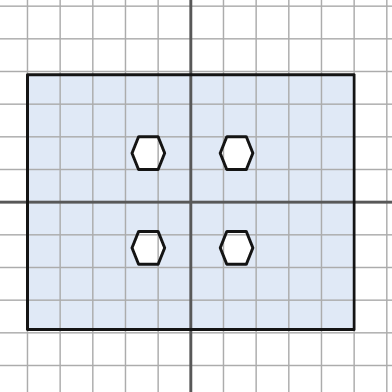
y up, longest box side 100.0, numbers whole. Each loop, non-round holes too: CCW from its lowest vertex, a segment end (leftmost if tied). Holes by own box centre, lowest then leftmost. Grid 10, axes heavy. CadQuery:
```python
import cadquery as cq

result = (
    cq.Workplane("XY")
    .moveTo(-50.0, -39.0)
    .lineTo(50.0, -39.0)
    .lineTo(50.0, 39.0)
    .lineTo(-50.0, 39.0)
    .close()
    .moveTo(-16.0, -19.0)
    .lineTo(-10.0, -19.0)
    .lineTo(-8.0, -14.0)
    .lineTo(-10.0, -9.0)
    .lineTo(-16.0, -9.0)
    .lineTo(-18.0, -14.0)
    .close()
    .moveTo(11.0, -19.0)
    .lineTo(17.0, -19.0)
    .lineTo(19.0, -14.0)
    .lineTo(17.0, -9.0)
    .lineTo(11.0, -9.0)
    .lineTo(9.0, -14.0)
    .close()
    .moveTo(-16.0, 10.0)
    .lineTo(-10.0, 10.0)
    .lineTo(-8.0, 15.0)
    .lineTo(-10.0, 20.0)
    .lineTo(-16.0, 20.0)
    .lineTo(-18.0, 15.0)
    .close()
    .moveTo(11.0, 10.0)
    .lineTo(17.0, 10.0)
    .lineTo(19.0, 15.0)
    .lineTo(17.0, 20.0)
    .lineTo(11.0, 20.0)
    .lineTo(9.0, 15.0)
    .close()
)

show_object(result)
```